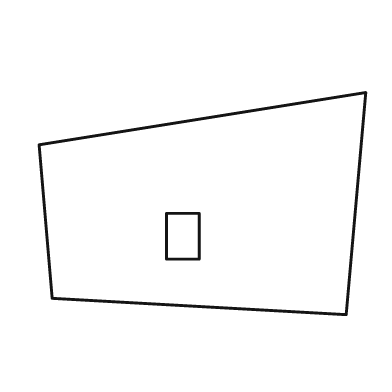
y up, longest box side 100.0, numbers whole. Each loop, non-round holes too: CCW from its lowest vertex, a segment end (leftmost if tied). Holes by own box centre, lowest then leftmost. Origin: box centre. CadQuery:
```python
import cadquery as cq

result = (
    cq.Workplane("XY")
    .moveTo(44.0, -34.0)
    .lineTo(50.0, 34.0)
    .lineTo(-50.0, 18.0)
    .lineTo(-46.0, -29.0)
    .close()
    .moveTo(-11.0, -17.0)
    .lineTo(-1.0, -17.0)
    .lineTo(-1.0, -3.0)
    .lineTo(-11.0, -3.0)
    .close()
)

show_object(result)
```